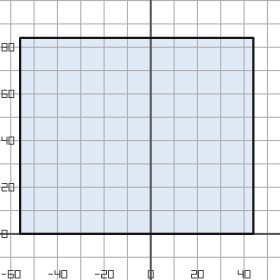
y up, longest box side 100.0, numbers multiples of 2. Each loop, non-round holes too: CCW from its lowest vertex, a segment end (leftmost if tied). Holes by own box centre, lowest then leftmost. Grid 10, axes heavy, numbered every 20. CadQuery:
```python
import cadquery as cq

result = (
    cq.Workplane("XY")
    .moveTo(-56.0, 0.0)
    .lineTo(44.0, 0.0)
    .lineTo(44.0, 84.0)
    .lineTo(-56.0, 84.0)
    .close()
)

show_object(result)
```